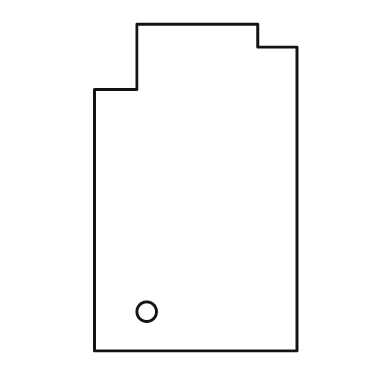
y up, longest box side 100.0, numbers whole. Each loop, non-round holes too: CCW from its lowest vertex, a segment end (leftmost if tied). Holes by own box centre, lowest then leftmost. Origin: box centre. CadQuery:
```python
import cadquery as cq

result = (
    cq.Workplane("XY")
    .moveTo(-31.0, -50.0)
    .lineTo(31.0, -50.0)
    .lineTo(31.0, 43.0)
    .lineTo(19.0, 43.0)
    .lineTo(19.0, 50.0)
    .lineTo(-18.0, 50.0)
    .lineTo(-18.0, 30.0)
    .lineTo(-31.0, 30.0)
    .close()
    .moveTo(-15.0, -38.0)
    .circle(3.0)
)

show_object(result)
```